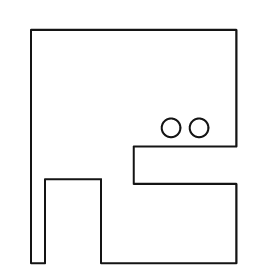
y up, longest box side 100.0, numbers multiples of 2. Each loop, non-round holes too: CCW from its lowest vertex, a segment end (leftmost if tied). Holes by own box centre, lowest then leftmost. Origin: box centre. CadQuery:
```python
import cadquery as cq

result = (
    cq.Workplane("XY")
    .moveTo(-44.0, -50.0)
    .lineTo(-38.0, -50.0)
    .lineTo(-38.0, -14.0)
    .lineTo(-14.0, -14.0)
    .lineTo(-14.0, -50.0)
    .lineTo(44.0, -50.0)
    .lineTo(44.0, -16.0)
    .lineTo(0.0, -16.0)
    .lineTo(0.0, 0.0)
    .lineTo(44.0, 0.0)
    .lineTo(44.0, 50.0)
    .lineTo(-44.0, 50.0)
    .close()
    .moveTo(16.0, 8.0)
    .circle(4.0)
    .moveTo(28.0, 8.0)
    .circle(4.0)
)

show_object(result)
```